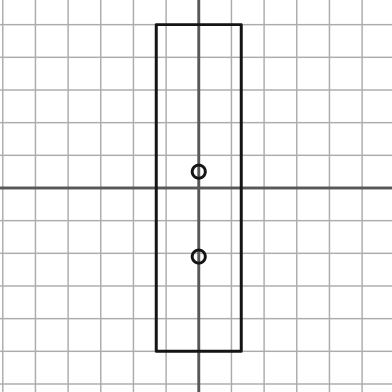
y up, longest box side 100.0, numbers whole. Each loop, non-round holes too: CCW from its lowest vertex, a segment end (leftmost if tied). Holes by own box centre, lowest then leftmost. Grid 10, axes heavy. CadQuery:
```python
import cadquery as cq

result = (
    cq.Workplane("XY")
    .moveTo(-13.0, -50.0)
    .lineTo(13.0, -50.0)
    .lineTo(13.0, 50.0)
    .lineTo(-13.0, 50.0)
    .close()
    .moveTo(0.0, -21.0)
    .circle(2.0)
    .moveTo(0.0, 5.0)
    .circle(2.0)
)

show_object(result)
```